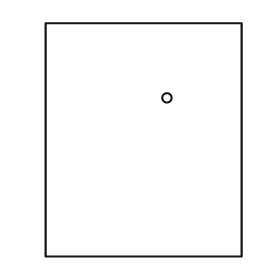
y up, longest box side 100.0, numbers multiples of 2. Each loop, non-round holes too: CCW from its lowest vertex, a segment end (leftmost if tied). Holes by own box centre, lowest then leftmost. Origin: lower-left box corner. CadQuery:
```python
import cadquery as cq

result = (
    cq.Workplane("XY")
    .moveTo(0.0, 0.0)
    .lineTo(84.0, 0.0)
    .lineTo(84.0, 100.0)
    .lineTo(0.0, 100.0)
    .close()
    .moveTo(52.0, 68.0)
    .circle(2.0)
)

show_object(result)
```